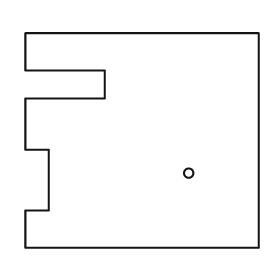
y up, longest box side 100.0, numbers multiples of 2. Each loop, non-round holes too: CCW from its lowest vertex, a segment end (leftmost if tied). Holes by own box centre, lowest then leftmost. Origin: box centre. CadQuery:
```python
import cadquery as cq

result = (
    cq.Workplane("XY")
    .moveTo(-50.0, -46.0)
    .lineTo(50.0, -46.0)
    .lineTo(50.0, 46.0)
    .lineTo(-50.0, 46.0)
    .lineTo(-50.0, 30.0)
    .lineTo(-16.0, 30.0)
    .lineTo(-16.0, 18.0)
    .lineTo(-50.0, 18.0)
    .lineTo(-50.0, -4.0)
    .lineTo(-40.0, -4.0)
    .lineTo(-40.0, -30.0)
    .lineTo(-50.0, -30.0)
    .close()
    .moveTo(20.0, -14.0)
    .circle(2.0)
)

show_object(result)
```